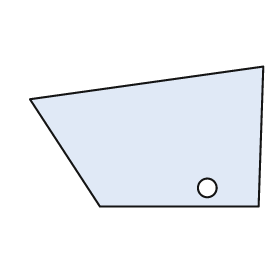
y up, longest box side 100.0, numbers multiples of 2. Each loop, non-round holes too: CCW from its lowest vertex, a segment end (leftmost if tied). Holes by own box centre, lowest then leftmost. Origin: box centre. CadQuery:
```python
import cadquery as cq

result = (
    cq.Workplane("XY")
    .moveTo(-20.0, -30.0)
    .lineTo(48.0, -30.0)
    .lineTo(50.0, 30.0)
    .lineTo(-50.0, 16.0)
    .close()
    .moveTo(26.0, -22.0)
    .circle(4.0)
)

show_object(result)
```